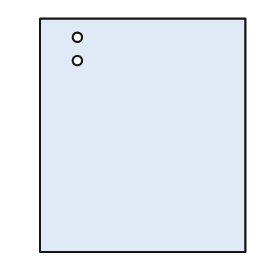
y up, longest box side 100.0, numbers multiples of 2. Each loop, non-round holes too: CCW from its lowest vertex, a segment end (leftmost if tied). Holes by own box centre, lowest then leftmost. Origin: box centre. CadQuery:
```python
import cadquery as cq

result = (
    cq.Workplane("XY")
    .moveTo(-44.0, -50.0)
    .lineTo(44.0, -50.0)
    .lineTo(44.0, 50.0)
    .lineTo(-44.0, 50.0)
    .close()
    .moveTo(-28.0, 32.0)
    .circle(2.0)
    .moveTo(-28.0, 42.0)
    .circle(2.0)
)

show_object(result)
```